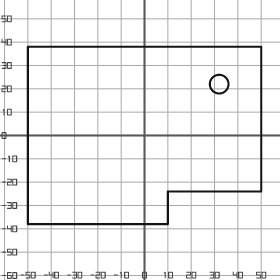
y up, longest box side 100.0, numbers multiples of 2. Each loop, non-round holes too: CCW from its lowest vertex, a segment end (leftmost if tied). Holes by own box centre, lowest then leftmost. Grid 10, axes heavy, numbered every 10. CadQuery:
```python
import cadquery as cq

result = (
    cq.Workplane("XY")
    .moveTo(-50.0, -38.0)
    .lineTo(10.0, -38.0)
    .lineTo(10.0, -24.0)
    .lineTo(50.0, -24.0)
    .lineTo(50.0, 38.0)
    .lineTo(-50.0, 38.0)
    .close()
    .moveTo(32.0, 22.0)
    .circle(4.0)
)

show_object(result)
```